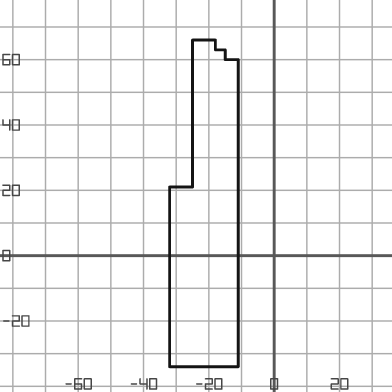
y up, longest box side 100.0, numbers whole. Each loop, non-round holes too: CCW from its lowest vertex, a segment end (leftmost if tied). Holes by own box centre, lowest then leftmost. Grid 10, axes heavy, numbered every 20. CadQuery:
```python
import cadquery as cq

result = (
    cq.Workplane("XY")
    .moveTo(-32.0, -34.0)
    .lineTo(-11.0, -34.0)
    .lineTo(-11.0, 60.0)
    .lineTo(-15.0, 60.0)
    .lineTo(-15.0, 63.0)
    .lineTo(-18.0, 63.0)
    .lineTo(-18.0, 66.0)
    .lineTo(-25.0, 66.0)
    .lineTo(-25.0, 21.0)
    .lineTo(-32.0, 21.0)
    .close()
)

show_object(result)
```